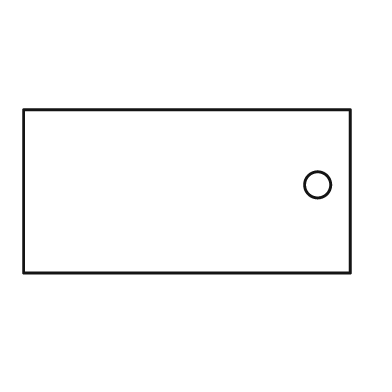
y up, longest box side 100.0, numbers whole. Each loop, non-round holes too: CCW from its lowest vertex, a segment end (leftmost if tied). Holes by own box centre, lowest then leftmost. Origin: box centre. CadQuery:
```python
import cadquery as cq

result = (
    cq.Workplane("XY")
    .moveTo(-50.0, -25.0)
    .lineTo(50.0, -25.0)
    .lineTo(50.0, 25.0)
    .lineTo(-50.0, 25.0)
    .close()
    .moveTo(40.0, 2.0)
    .circle(4.0)
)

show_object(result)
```